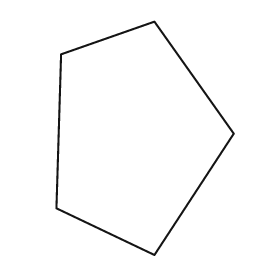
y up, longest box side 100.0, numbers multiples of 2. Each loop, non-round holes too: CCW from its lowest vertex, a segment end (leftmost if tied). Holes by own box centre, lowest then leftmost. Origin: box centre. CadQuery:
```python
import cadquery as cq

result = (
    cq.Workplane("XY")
    .moveTo(4.0, -50.0)
    .lineTo(38.0, 2.0)
    .lineTo(4.0, 50.0)
    .lineTo(-36.0, 36.0)
    .lineTo(-38.0, -30.0)
    .close()
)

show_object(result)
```